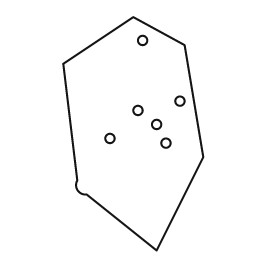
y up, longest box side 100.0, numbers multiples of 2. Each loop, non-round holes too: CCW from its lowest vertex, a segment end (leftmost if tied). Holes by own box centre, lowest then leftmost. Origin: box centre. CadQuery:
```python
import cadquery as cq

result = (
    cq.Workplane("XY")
    .moveTo(10.0, -50.0)
    .lineTo(30.0, -10.0)
    .lineTo(22.0, 38.0)
    .lineTo(0.0, 50.0)
    .lineTo(-30.0, 30.0)
    .lineTo(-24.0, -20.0)
    .threePointArc((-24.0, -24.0), (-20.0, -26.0))
    .close()
    .moveTo(14.0, -4.0)
    .circle(2.0)
    .moveTo(-10.0, -2.0)
    .circle(2.0)
    .moveTo(10.0, 4.0)
    .circle(2.0)
    .moveTo(2.0, 10.0)
    .circle(2.0)
    .moveTo(20.0, 14.0)
    .circle(2.0)
    .moveTo(4.0, 40.0)
    .circle(2.0)
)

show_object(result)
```